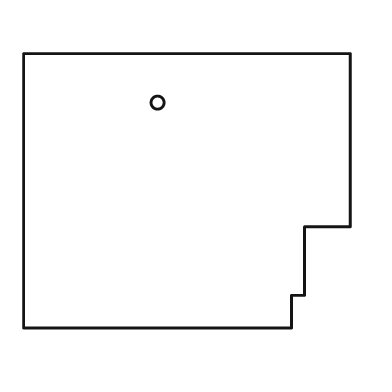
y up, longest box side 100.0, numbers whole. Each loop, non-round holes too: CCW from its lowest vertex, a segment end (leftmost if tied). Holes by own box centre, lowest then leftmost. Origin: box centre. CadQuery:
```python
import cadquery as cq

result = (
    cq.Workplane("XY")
    .moveTo(-50.0, -42.0)
    .lineTo(32.0, -42.0)
    .lineTo(32.0, -32.0)
    .lineTo(36.0, -32.0)
    .lineTo(36.0, -11.0)
    .lineTo(50.0, -11.0)
    .lineTo(50.0, 42.0)
    .lineTo(-50.0, 42.0)
    .close()
    .moveTo(-9.0, 27.0)
    .circle(2.0)
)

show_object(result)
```